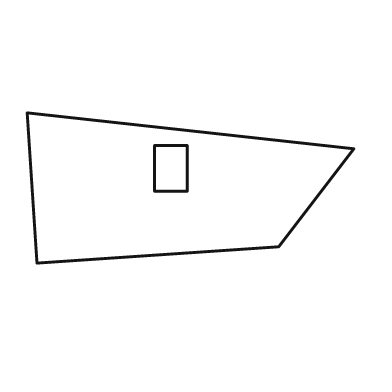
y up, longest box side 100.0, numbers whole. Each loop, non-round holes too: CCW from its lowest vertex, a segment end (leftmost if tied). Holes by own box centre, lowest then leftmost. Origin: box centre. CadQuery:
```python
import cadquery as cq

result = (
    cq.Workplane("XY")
    .moveTo(-47.0, -23.0)
    .lineTo(27.0, -18.0)
    .lineTo(50.0, 12.0)
    .lineTo(-50.0, 23.0)
    .close()
    .moveTo(-11.0, -1.0)
    .lineTo(-1.0, -1.0)
    .lineTo(-1.0, 13.0)
    .lineTo(-11.0, 13.0)
    .close()
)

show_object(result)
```